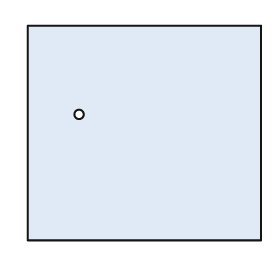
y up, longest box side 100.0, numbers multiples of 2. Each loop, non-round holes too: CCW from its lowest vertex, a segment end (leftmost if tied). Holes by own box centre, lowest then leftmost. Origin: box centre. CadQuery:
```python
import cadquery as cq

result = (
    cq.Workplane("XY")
    .moveTo(-50.0, -46.0)
    .lineTo(50.0, -46.0)
    .lineTo(50.0, 46.0)
    .lineTo(-50.0, 46.0)
    .close()
    .moveTo(-28.0, 8.0)
    .circle(2.0)
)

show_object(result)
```